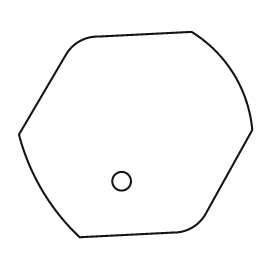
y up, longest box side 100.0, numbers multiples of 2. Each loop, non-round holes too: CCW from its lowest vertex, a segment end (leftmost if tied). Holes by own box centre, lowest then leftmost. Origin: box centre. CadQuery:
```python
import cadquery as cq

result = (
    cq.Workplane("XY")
    .moveTo(-24.0, -44.0)
    .lineTo(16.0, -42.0)
    .threePointArc((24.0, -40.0), (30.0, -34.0))
    .lineTo(50.0, 2.0)
    .threePointArc((42.0, 26.0), (24.0, 44.0))
    .lineTo(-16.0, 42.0)
    .threePointArc((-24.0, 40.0), (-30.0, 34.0))
    .lineTo(-50.0, 0.0)
    .threePointArc((-40.0, -24.0), (-24.0, -44.0))
    .close()
    .moveTo(-6.0, -20.0)
    .circle(4.0)
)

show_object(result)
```